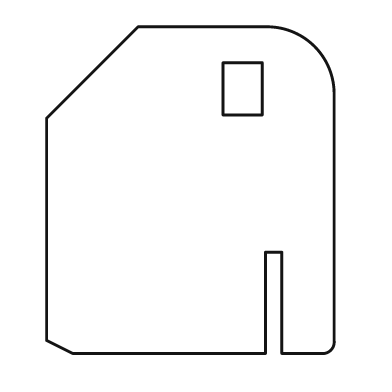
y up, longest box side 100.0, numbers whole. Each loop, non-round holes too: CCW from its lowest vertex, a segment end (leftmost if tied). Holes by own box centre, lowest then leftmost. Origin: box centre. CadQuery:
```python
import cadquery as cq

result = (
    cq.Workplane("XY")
    .moveTo(-36.0, -50.0)
    .lineTo(23.0, -50.0)
    .lineTo(23.0, -19.0)
    .lineTo(28.0, -19.0)
    .lineTo(28.0, -50.0)
    .lineTo(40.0, -50.0)
    .threePointArc((43.0, -49.0), (44.0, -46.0))
    .lineTo(44.0, 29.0)
    .threePointArc((38.0, 44.0), (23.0, 50.0))
    .lineTo(-16.0, 50.0)
    .lineTo(-44.0, 22.0)
    .lineTo(-44.0, -46.0)
    .close()
    .moveTo(10.0, 23.0)
    .lineTo(22.0, 23.0)
    .lineTo(22.0, 39.0)
    .lineTo(10.0, 39.0)
    .close()
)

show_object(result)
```